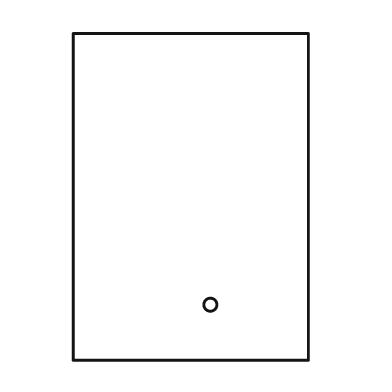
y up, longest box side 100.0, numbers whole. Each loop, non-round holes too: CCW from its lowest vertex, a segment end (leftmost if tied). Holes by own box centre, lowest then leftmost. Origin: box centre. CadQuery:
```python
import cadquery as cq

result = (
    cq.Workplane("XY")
    .moveTo(-36.0, -50.0)
    .lineTo(36.0, -50.0)
    .lineTo(36.0, 50.0)
    .lineTo(-36.0, 50.0)
    .close()
    .moveTo(6.0, -33.0)
    .circle(2.0)
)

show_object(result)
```